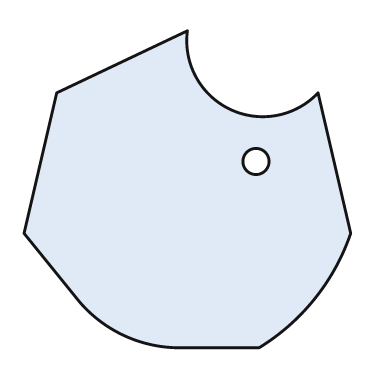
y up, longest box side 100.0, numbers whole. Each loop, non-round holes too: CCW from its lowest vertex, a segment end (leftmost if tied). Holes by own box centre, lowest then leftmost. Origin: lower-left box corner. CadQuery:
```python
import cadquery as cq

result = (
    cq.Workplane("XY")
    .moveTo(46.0, 0.0)
    .lineTo(72.0, 0.0)
    .threePointArc((89.0, 15.0), (100.0, 35.0))
    .lineTo(90.0, 78.0)
    .threePointArc((63.0, 73.0), (50.0, 97.0))
    .lineTo(10.0, 78.0)
    .lineTo(0.0, 35.0)
    .lineTo(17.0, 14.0)
    .threePointArc((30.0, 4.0), (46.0, 0.0))
    .close()
    .moveTo(71.0, 57.0)
    .circle(4.0)
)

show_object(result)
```